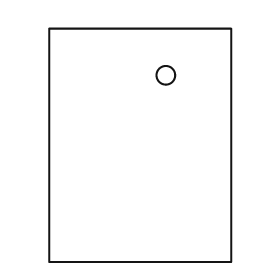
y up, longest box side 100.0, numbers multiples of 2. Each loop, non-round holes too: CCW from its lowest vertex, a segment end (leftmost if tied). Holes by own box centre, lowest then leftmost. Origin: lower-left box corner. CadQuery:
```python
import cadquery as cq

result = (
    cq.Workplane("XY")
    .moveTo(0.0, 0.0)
    .lineTo(78.0, 0.0)
    .lineTo(78.0, 100.0)
    .lineTo(0.0, 100.0)
    .close()
    .moveTo(50.0, 80.0)
    .circle(4.0)
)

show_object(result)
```